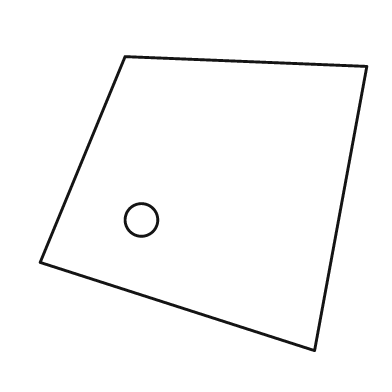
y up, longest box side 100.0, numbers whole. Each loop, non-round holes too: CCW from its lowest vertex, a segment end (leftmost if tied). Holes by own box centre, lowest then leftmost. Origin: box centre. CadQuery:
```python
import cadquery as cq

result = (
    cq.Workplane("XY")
    .moveTo(34.0, -45.0)
    .lineTo(50.0, 42.0)
    .lineTo(-24.0, 45.0)
    .lineTo(-50.0, -18.0)
    .close()
    .moveTo(-19.0, -5.0)
    .circle(5.0)
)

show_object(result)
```